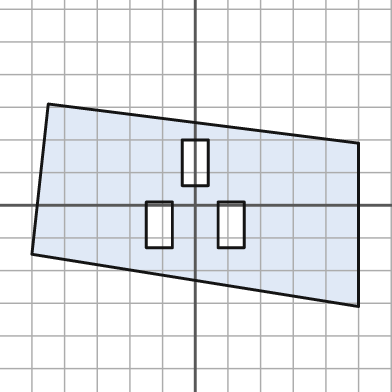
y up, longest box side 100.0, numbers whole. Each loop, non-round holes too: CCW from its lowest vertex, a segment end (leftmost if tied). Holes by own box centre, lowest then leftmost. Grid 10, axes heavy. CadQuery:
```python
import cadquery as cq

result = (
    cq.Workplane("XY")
    .moveTo(50.0, -31.0)
    .lineTo(50.0, 19.0)
    .lineTo(-45.0, 31.0)
    .lineTo(-50.0, -15.0)
    .close()
    .moveTo(-15.0, -13.0)
    .lineTo(-7.0, -13.0)
    .lineTo(-7.0, 1.0)
    .lineTo(-15.0, 1.0)
    .close()
    .moveTo(7.0, -13.0)
    .lineTo(15.0, -13.0)
    .lineTo(15.0, 1.0)
    .lineTo(7.0, 1.0)
    .close()
    .moveTo(-4.0, 6.0)
    .lineTo(4.0, 6.0)
    .lineTo(4.0, 20.0)
    .lineTo(-4.0, 20.0)
    .close()
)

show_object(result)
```